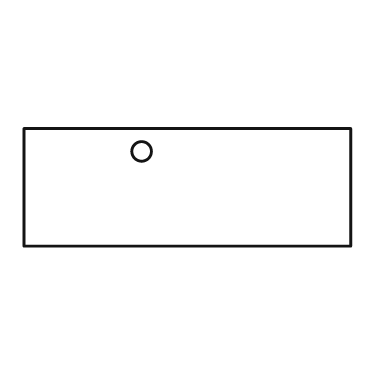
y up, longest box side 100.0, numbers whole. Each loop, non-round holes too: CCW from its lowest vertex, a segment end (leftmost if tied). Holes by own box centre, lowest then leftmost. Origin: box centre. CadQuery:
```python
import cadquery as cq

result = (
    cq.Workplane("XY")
    .moveTo(-50.0, -18.0)
    .lineTo(50.0, -18.0)
    .lineTo(50.0, 18.0)
    .lineTo(-50.0, 18.0)
    .close()
    .moveTo(-14.0, 11.0)
    .circle(3.0)
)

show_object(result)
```